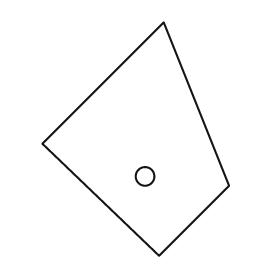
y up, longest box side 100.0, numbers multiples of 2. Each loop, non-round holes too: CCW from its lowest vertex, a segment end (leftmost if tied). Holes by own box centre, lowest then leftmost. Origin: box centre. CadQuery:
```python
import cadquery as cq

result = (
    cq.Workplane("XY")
    .moveTo(10.0, -50.0)
    .lineTo(40.0, -20.0)
    .lineTo(12.0, 50.0)
    .lineTo(-40.0, -2.0)
    .close()
    .moveTo(4.0, -16.0)
    .circle(4.0)
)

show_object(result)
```